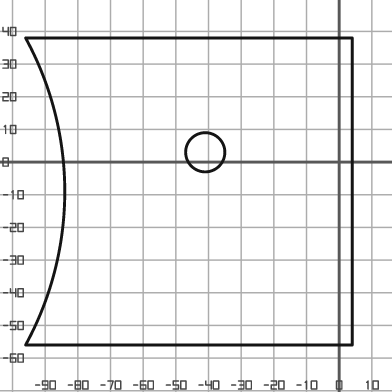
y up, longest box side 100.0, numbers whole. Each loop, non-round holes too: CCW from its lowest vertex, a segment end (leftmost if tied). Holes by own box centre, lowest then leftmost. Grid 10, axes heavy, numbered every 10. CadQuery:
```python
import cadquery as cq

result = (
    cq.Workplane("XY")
    .moveTo(-96.0, -56.0)
    .lineTo(4.0, -56.0)
    .lineTo(4.0, 38.0)
    .lineTo(-96.0, 38.0)
    .threePointArc((-84.0, -9.0), (-96.0, -56.0))
    .close()
    .moveTo(-41.0, 3.0)
    .circle(6.0)
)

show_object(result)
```